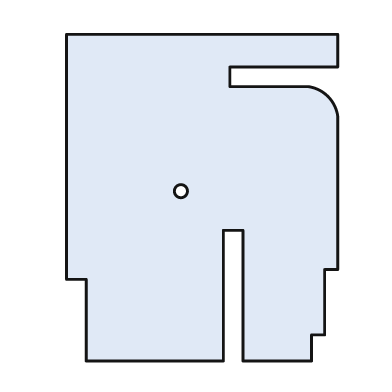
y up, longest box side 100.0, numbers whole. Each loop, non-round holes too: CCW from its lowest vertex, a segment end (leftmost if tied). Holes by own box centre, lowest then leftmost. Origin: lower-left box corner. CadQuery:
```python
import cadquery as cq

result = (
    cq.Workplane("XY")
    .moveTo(6.0, 0.0)
    .lineTo(48.0, 0.0)
    .lineTo(48.0, 40.0)
    .lineTo(54.0, 40.0)
    .lineTo(54.0, 0.0)
    .lineTo(75.0, 0.0)
    .lineTo(75.0, 8.0)
    .lineTo(79.0, 8.0)
    .lineTo(79.0, 28.0)
    .lineTo(83.0, 28.0)
    .lineTo(83.0, 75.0)
    .threePointArc((80.0, 81.0), (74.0, 84.0))
    .lineTo(50.0, 84.0)
    .lineTo(50.0, 90.0)
    .lineTo(83.0, 90.0)
    .lineTo(83.0, 100.0)
    .lineTo(0.0, 100.0)
    .lineTo(0.0, 25.0)
    .lineTo(6.0, 25.0)
    .close()
    .moveTo(35.0, 52.0)
    .circle(2.0)
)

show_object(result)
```